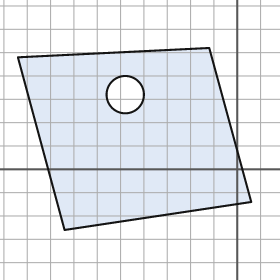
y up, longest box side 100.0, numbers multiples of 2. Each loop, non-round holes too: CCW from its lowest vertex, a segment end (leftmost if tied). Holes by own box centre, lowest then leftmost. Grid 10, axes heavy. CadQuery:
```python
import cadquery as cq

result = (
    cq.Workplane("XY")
    .moveTo(-74.0, -26.0)
    .lineTo(6.0, -14.0)
    .lineTo(-12.0, 52.0)
    .lineTo(-94.0, 48.0)
    .close()
    .moveTo(-48.0, 32.0)
    .circle(8.0)
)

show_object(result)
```